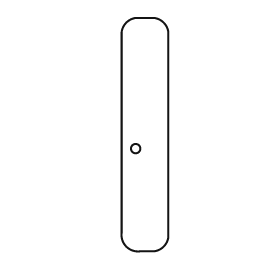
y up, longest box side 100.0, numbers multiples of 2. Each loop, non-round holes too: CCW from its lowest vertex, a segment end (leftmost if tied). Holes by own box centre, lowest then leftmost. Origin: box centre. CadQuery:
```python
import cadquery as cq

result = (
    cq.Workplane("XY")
    .moveTo(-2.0, -50.0)
    .lineTo(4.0, -50.0)
    .threePointArc((8.0, -48.0), (10.0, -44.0))
    .lineTo(10.0, 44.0)
    .threePointArc((8.0, 48.0), (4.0, 50.0))
    .lineTo(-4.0, 50.0)
    .threePointArc((-8.0, 48.0), (-10.0, 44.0))
    .lineTo(-10.0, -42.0)
    .threePointArc((-8.0, -48.0), (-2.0, -50.0))
    .close()
    .moveTo(-4.0, -6.0)
    .circle(2.0)
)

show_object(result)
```